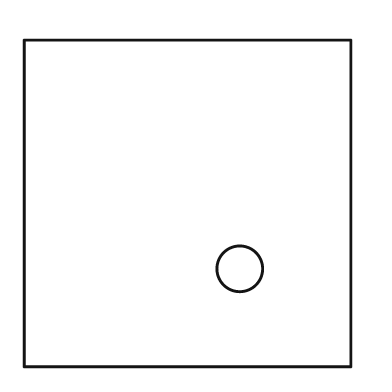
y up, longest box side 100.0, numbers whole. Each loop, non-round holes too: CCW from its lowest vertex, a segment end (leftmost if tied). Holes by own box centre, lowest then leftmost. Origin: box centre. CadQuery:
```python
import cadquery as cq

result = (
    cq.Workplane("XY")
    .moveTo(-50.0, -50.0)
    .lineTo(50.0, -50.0)
    .lineTo(50.0, 50.0)
    .lineTo(-50.0, 50.0)
    .close()
    .moveTo(16.0, -20.0)
    .circle(7.0)
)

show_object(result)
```